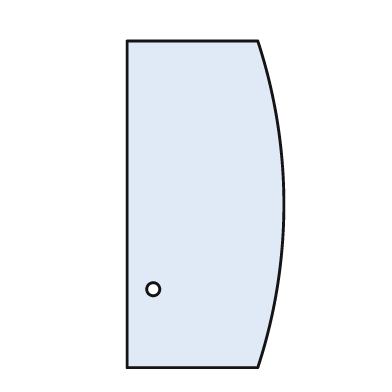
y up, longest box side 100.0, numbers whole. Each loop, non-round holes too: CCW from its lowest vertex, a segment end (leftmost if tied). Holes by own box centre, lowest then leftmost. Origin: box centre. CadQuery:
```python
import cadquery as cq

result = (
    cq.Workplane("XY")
    .moveTo(-24.0, -50.0)
    .lineTo(16.0, -50.0)
    .threePointArc((24.0, 0.0), (16.0, 50.0))
    .lineTo(-24.0, 50.0)
    .close()
    .moveTo(-16.0, -26.0)
    .circle(2.0)
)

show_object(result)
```